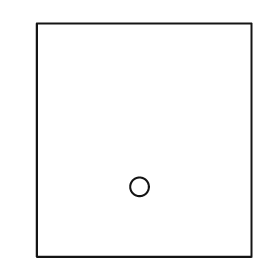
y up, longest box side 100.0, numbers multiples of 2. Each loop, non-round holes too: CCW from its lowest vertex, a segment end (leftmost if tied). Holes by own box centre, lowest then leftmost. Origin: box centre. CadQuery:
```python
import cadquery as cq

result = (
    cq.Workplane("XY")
    .moveTo(-46.0, -50.0)
    .lineTo(46.0, -50.0)
    .lineTo(46.0, 50.0)
    .lineTo(-46.0, 50.0)
    .close()
    .moveTo(-2.0, -20.0)
    .circle(4.0)
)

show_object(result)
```